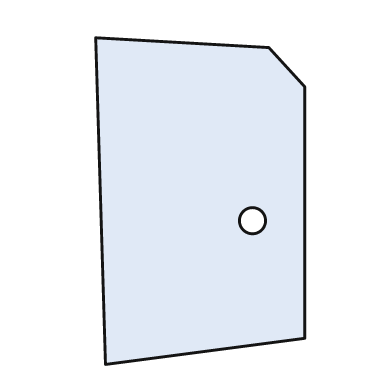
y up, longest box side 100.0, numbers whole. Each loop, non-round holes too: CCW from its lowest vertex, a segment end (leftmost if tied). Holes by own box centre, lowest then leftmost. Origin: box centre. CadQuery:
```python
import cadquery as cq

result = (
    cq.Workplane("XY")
    .moveTo(-29.0, -50.0)
    .lineTo(32.0, -42.0)
    .lineTo(32.0, 35.0)
    .lineTo(21.0, 47.0)
    .lineTo(-32.0, 50.0)
    .close()
    .moveTo(16.0, -6.0)
    .circle(4.0)
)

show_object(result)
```